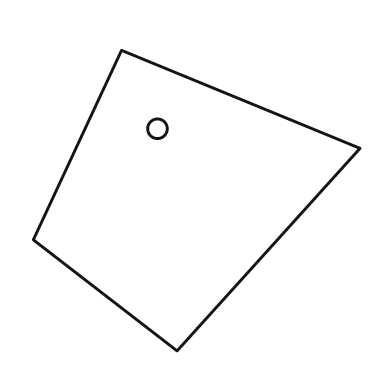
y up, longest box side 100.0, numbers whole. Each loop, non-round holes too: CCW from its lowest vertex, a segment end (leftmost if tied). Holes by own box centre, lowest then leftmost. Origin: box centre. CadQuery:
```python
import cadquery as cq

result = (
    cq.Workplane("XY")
    .moveTo(-6.0, -46.0)
    .lineTo(50.0, 16.0)
    .lineTo(-23.0, 46.0)
    .lineTo(-50.0, -12.0)
    .close()
    .moveTo(-12.0, 22.0)
    .circle(3.0)
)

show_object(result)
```